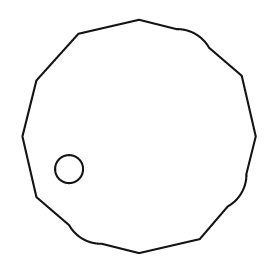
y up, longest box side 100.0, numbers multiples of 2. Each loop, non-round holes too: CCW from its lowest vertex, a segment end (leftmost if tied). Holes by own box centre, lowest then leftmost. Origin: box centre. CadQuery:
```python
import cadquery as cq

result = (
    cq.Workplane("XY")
    .moveTo(0.0, -50.0)
    .lineTo(26.0, -44.0)
    .lineTo(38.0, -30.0)
    .threePointArc((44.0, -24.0), (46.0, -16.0))
    .lineTo(50.0, 0.0)
    .lineTo(44.0, 26.0)
    .lineTo(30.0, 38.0)
    .threePointArc((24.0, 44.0), (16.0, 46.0))
    .lineTo(0.0, 50.0)
    .lineTo(-26.0, 44.0)
    .lineTo(-44.0, 24.0)
    .lineTo(-50.0, 0.0)
    .lineTo(-44.0, -26.0)
    .lineTo(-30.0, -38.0)
    .threePointArc((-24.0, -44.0), (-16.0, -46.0))
    .close()
    .moveTo(-30.0, -14.0)
    .circle(6.0)
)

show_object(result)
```